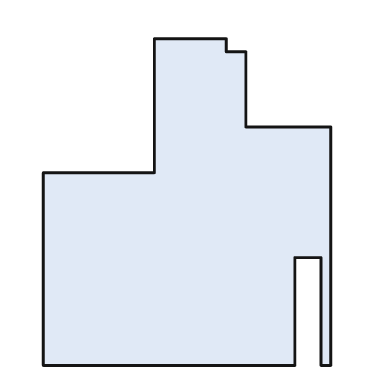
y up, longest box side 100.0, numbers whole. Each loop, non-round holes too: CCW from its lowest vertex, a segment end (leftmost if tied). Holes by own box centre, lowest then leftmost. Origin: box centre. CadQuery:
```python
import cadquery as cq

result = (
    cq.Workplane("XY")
    .moveTo(-44.0, -50.0)
    .lineTo(33.0, -50.0)
    .lineTo(33.0, -17.0)
    .lineTo(41.0, -17.0)
    .lineTo(41.0, -50.0)
    .lineTo(44.0, -50.0)
    .lineTo(44.0, 23.0)
    .lineTo(18.0, 23.0)
    .lineTo(18.0, 46.0)
    .lineTo(12.0, 46.0)
    .lineTo(12.0, 50.0)
    .lineTo(-10.0, 50.0)
    .lineTo(-10.0, 9.0)
    .lineTo(-44.0, 9.0)
    .close()
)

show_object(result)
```